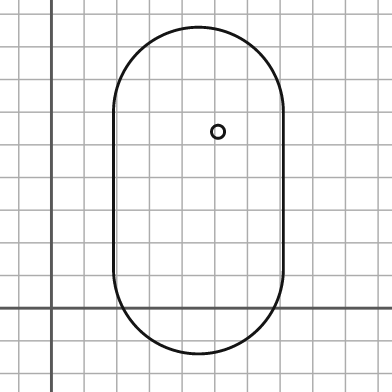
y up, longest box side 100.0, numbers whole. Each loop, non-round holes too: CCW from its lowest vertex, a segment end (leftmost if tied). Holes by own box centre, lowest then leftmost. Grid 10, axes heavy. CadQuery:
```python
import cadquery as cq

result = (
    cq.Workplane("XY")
    .moveTo(19.0, 12.0)
    .threePointArc((45.0, -14.0), (71.0, 12.0))
    .lineTo(71.0, 60.0)
    .threePointArc((45.0, 86.0), (19.0, 60.0))
    .close()
    .moveTo(51.0, 54.0)
    .circle(2.0)
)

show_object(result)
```